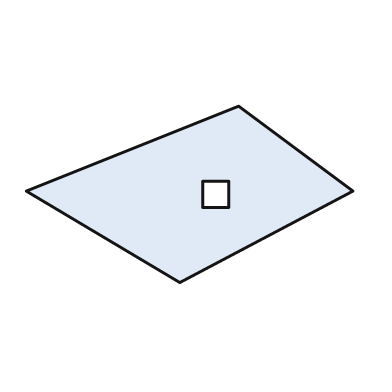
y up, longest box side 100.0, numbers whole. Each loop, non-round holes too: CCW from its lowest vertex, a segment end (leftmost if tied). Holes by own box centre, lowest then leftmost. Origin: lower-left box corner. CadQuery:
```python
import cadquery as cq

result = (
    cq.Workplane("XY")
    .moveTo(47.0, 0.0)
    .lineTo(100.0, 28.0)
    .lineTo(65.0, 54.0)
    .lineTo(0.0, 28.0)
    .close()
    .moveTo(54.0, 23.0)
    .lineTo(62.0, 23.0)
    .lineTo(62.0, 31.0)
    .lineTo(54.0, 31.0)
    .close()
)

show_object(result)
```